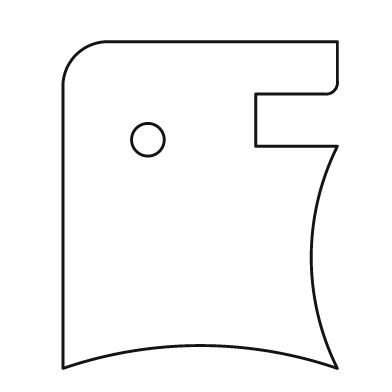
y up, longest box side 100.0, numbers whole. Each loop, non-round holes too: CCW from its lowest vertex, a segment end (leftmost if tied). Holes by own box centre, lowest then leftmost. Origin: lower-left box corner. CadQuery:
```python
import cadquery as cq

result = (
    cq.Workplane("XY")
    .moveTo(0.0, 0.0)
    .threePointArc((42.0, 7.0), (84.0, 0.0))
    .threePointArc((76.0, 34.0), (84.0, 68.0))
    .lineTo(59.0, 68.0)
    .lineTo(59.0, 84.0)
    .lineTo(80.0, 84.0)
    .threePointArc((83.0, 85.0), (84.0, 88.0))
    .lineTo(84.0, 100.0)
    .lineTo(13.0, 100.0)
    .threePointArc((4.0, 96.0), (0.0, 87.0))
    .close()
    .moveTo(26.0, 70.0)
    .circle(5.0)
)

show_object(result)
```